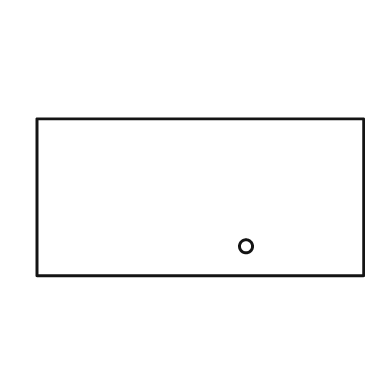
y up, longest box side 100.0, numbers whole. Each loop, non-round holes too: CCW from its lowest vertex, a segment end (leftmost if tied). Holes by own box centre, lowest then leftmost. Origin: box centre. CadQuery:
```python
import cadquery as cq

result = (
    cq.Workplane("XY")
    .moveTo(-50.0, -24.0)
    .lineTo(50.0, -24.0)
    .lineTo(50.0, 24.0)
    .lineTo(-50.0, 24.0)
    .close()
    .moveTo(14.0, -15.0)
    .circle(2.0)
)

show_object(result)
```